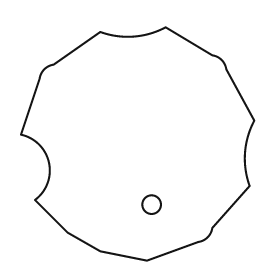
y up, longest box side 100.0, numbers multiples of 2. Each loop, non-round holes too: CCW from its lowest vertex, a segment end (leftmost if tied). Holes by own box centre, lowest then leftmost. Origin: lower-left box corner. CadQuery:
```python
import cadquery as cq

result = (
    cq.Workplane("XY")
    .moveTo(54.0, 0.0)
    .lineTo(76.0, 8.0)
    .threePointArc((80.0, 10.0), (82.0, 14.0))
    .lineTo(98.0, 32.0)
    .threePointArc((96.0, 46.0), (100.0, 60.0))
    .lineTo(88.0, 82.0)
    .threePointArc((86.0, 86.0), (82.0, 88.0))
    .lineTo(62.0, 100.0)
    .threePointArc((48.0, 96.0), (34.0, 98.0))
    .lineTo(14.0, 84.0)
    .threePointArc((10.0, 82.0), (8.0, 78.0))
    .lineTo(0.0, 54.0)
    .threePointArc((12.0, 42.0), (6.0, 26.0))
    .lineTo(20.0, 12.0)
    .lineTo(34.0, 4.0)
    .close()
    .moveTo(56.0, 24.0)
    .circle(4.0)
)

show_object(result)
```